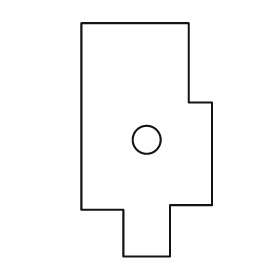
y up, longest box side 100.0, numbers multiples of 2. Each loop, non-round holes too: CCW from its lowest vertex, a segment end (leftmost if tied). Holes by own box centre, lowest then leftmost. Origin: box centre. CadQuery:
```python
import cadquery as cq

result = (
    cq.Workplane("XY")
    .moveTo(-10.0, -50.0)
    .lineTo(10.0, -50.0)
    .lineTo(10.0, -28.0)
    .lineTo(28.0, -28.0)
    .lineTo(28.0, 16.0)
    .lineTo(18.0, 16.0)
    .lineTo(18.0, 50.0)
    .lineTo(-28.0, 50.0)
    .lineTo(-28.0, -30.0)
    .lineTo(-10.0, -30.0)
    .close()
    .moveTo(0.0, 0.0)
    .circle(6.0)
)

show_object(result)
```